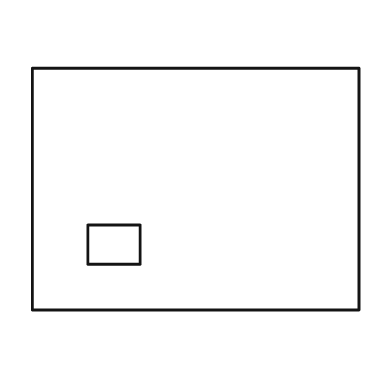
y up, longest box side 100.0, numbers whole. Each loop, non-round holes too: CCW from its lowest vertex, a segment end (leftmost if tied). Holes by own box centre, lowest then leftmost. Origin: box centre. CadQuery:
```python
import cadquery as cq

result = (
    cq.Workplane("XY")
    .moveTo(-50.0, -37.0)
    .lineTo(50.0, -37.0)
    .lineTo(50.0, 37.0)
    .lineTo(-50.0, 37.0)
    .close()
    .moveTo(-33.0, -23.0)
    .lineTo(-17.0, -23.0)
    .lineTo(-17.0, -11.0)
    .lineTo(-33.0, -11.0)
    .close()
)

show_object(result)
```